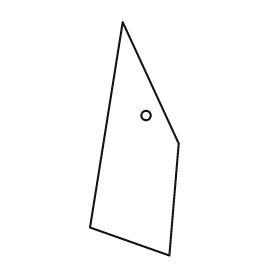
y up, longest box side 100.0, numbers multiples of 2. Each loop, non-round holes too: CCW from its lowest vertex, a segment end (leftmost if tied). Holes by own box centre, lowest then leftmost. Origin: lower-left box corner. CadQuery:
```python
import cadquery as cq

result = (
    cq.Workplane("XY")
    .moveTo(34.0, 0.0)
    .lineTo(38.0, 48.0)
    .lineTo(14.0, 100.0)
    .lineTo(0.0, 12.0)
    .close()
    .moveTo(24.0, 60.0)
    .circle(2.0)
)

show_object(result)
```